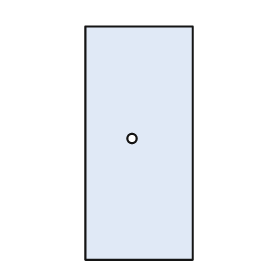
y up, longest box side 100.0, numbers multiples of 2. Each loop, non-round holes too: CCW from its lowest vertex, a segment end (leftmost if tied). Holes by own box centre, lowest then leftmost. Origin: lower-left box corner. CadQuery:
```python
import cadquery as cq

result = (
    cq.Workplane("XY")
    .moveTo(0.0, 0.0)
    .lineTo(46.0, 0.0)
    .lineTo(46.0, 100.0)
    .lineTo(0.0, 100.0)
    .close()
    .moveTo(20.0, 52.0)
    .circle(2.0)
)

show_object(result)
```